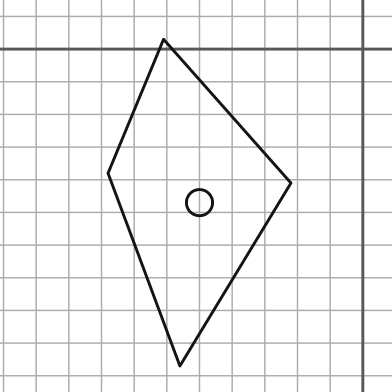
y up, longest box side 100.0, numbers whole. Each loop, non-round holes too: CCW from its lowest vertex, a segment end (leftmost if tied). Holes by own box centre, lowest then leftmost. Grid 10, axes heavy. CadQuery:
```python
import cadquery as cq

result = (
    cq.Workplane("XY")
    .moveTo(-56.0, -97.0)
    .lineTo(-22.0, -41.0)
    .lineTo(-61.0, 3.0)
    .lineTo(-78.0, -38.0)
    .close()
    .moveTo(-50.0, -47.0)
    .circle(4.0)
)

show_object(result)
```